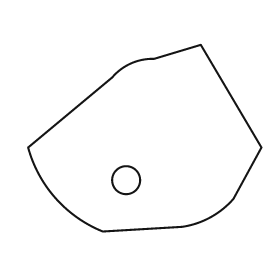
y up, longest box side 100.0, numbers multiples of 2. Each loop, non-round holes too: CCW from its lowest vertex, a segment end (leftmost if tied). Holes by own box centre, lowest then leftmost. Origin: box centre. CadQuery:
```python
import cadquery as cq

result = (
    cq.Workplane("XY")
    .moveTo(-18.0, -40.0)
    .lineTo(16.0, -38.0)
    .threePointArc((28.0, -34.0), (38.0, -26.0))
    .lineTo(50.0, -4.0)
    .lineTo(24.0, 40.0)
    .lineTo(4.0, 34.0)
    .threePointArc((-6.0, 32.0), (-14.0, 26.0))
    .lineTo(-50.0, -4.0)
    .threePointArc((-38.0, -26.0), (-18.0, -40.0))
    .close()
    .moveTo(-8.0, -18.0)
    .circle(6.0)
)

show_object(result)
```